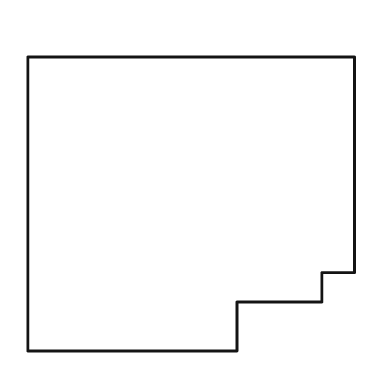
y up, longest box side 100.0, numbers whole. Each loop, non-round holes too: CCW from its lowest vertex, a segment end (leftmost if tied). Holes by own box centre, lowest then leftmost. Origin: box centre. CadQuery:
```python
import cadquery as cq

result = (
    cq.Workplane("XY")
    .moveTo(-50.0, -45.0)
    .lineTo(14.0, -45.0)
    .lineTo(14.0, -30.0)
    .lineTo(40.0, -30.0)
    .lineTo(40.0, -21.0)
    .lineTo(50.0, -21.0)
    .lineTo(50.0, 45.0)
    .lineTo(-50.0, 45.0)
    .close()
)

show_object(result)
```